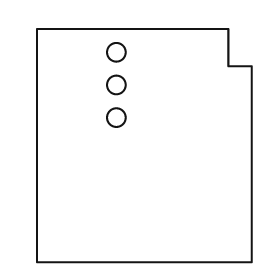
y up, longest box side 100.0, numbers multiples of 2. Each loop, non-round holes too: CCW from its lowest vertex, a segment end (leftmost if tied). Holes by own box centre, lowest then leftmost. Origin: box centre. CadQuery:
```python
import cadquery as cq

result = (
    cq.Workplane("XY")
    .moveTo(-46.0, -50.0)
    .lineTo(46.0, -50.0)
    .lineTo(46.0, 34.0)
    .lineTo(36.0, 34.0)
    .lineTo(36.0, 50.0)
    .lineTo(-46.0, 50.0)
    .close()
    .moveTo(-12.0, 12.0)
    .circle(4.0)
    .moveTo(-12.0, 26.0)
    .circle(4.0)
    .moveTo(-12.0, 40.0)
    .circle(4.0)
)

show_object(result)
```